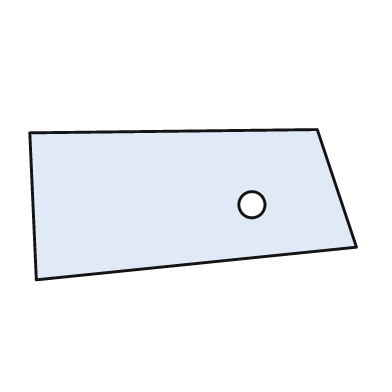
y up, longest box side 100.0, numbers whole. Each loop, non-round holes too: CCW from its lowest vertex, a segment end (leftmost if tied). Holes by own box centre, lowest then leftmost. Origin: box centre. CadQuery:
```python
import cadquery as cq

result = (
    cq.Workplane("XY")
    .moveTo(-48.0, -23.0)
    .lineTo(50.0, -13.0)
    .lineTo(38.0, 23.0)
    .lineTo(-50.0, 22.0)
    .close()
    .moveTo(18.0, 0.0)
    .circle(4.0)
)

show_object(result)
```